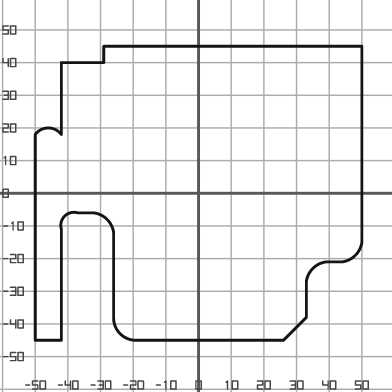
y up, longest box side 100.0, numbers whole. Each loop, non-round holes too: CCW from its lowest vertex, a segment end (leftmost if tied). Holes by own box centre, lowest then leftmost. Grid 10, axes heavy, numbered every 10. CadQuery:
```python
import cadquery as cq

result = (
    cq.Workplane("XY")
    .moveTo(-50.0, -45.0)
    .lineTo(-42.0, -45.0)
    .lineTo(-42.0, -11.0)
    .threePointArc((-41.0, -7.0), (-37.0, -6.0))
    .lineTo(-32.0, -6.0)
    .threePointArc((-28.0, -8.0), (-26.0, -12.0))
    .lineTo(-26.0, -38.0)
    .threePointArc((-24.0, -43.0), (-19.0, -45.0))
    .lineTo(26.0, -45.0)
    .lineTo(33.0, -38.0)
    .lineTo(33.0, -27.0)
    .threePointArc((35.0, -23.0), (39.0, -21.0))
    .lineTo(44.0, -21.0)
    .threePointArc((48.0, -19.0), (50.0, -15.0))
    .lineTo(50.0, 45.0)
    .lineTo(-29.0, 45.0)
    .lineTo(-29.0, 40.0)
    .lineTo(-42.0, 40.0)
    .lineTo(-42.0, 18.0)
    .threePointArc((-46.0, 20.0), (-50.0, 18.0))
    .close()
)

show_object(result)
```